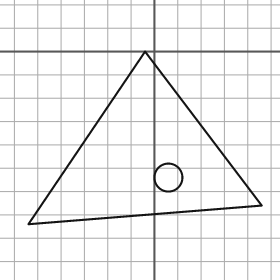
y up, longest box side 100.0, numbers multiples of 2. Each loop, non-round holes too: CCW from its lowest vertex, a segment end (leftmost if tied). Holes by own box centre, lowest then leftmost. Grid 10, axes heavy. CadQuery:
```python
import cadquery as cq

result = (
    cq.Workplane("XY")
    .moveTo(-54.0, -74.0)
    .lineTo(46.0, -66.0)
    .lineTo(-4.0, 0.0)
    .close()
    .moveTo(6.0, -54.0)
    .circle(6.0)
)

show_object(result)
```